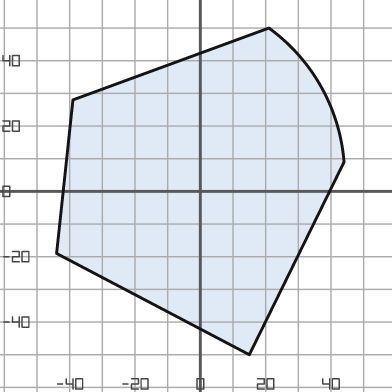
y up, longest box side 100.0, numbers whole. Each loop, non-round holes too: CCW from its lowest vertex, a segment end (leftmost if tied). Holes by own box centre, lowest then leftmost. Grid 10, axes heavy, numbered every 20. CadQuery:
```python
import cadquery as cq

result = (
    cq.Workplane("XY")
    .moveTo(15.0, -50.0)
    .lineTo(44.0, 9.0)
    .threePointArc((37.0, 32.0), (21.0, 50.0))
    .lineTo(-39.0, 28.0)
    .lineTo(-44.0, -19.0)
    .close()
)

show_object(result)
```